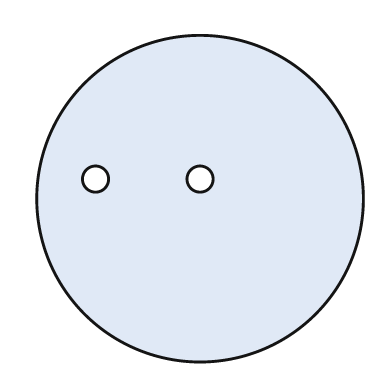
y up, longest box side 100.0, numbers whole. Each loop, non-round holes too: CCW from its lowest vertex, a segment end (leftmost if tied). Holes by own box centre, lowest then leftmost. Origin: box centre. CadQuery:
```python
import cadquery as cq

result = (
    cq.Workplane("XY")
    .moveTo(0.0, 0.0)
    .circle(50.0)
    .moveTo(-32.0, 6.0)
    .circle(4.0)
    .moveTo(0.0, 6.0)
    .circle(4.0)
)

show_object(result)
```